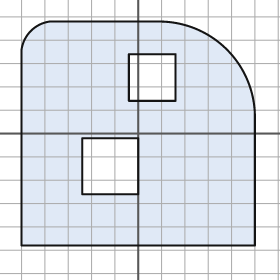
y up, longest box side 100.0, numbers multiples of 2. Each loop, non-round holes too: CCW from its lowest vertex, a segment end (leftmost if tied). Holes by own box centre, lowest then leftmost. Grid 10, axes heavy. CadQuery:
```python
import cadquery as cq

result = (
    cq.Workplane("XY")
    .moveTo(-50.0, -48.0)
    .lineTo(50.0, -48.0)
    .lineTo(50.0, 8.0)
    .threePointArc((38.0, 36.0), (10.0, 48.0))
    .lineTo(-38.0, 48.0)
    .threePointArc((-46.0, 44.0), (-50.0, 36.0))
    .close()
    .moveTo(-24.0, -26.0)
    .lineTo(0.0, -26.0)
    .lineTo(0.0, -2.0)
    .lineTo(-24.0, -2.0)
    .close()
    .moveTo(-4.0, 14.0)
    .lineTo(16.0, 14.0)
    .lineTo(16.0, 34.0)
    .lineTo(-4.0, 34.0)
    .close()
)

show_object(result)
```